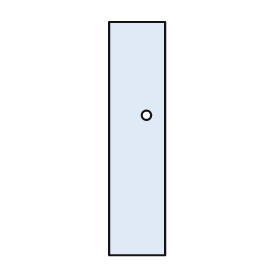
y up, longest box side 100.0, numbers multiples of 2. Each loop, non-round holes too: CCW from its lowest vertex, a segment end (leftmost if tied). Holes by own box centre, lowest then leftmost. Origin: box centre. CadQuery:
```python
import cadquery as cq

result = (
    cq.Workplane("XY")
    .moveTo(-12.0, -50.0)
    .lineTo(12.0, -50.0)
    .lineTo(12.0, 50.0)
    .lineTo(-12.0, 50.0)
    .close()
    .moveTo(4.0, 10.0)
    .circle(2.0)
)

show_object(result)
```